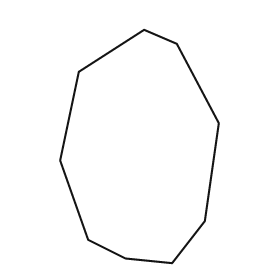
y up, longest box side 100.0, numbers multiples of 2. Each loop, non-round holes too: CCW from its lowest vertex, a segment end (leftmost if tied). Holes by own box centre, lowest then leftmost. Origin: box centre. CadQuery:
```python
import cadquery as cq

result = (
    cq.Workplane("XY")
    .moveTo(14.0, -50.0)
    .lineTo(28.0, -32.0)
    .lineTo(34.0, 10.0)
    .lineTo(16.0, 44.0)
    .lineTo(2.0, 50.0)
    .lineTo(-26.0, 32.0)
    .lineTo(-34.0, -6.0)
    .lineTo(-22.0, -40.0)
    .lineTo(-6.0, -48.0)
    .close()
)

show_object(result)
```